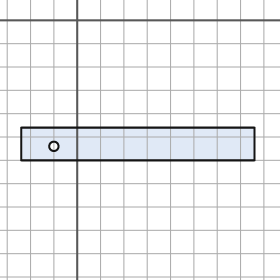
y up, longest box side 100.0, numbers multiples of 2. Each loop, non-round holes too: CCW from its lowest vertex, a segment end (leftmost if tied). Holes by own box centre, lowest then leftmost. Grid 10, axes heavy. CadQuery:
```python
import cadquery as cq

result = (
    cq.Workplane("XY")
    .moveTo(-24.0, -60.0)
    .lineTo(76.0, -60.0)
    .lineTo(76.0, -46.0)
    .lineTo(-24.0, -46.0)
    .close()
    .moveTo(-10.0, -54.0)
    .circle(2.0)
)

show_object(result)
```